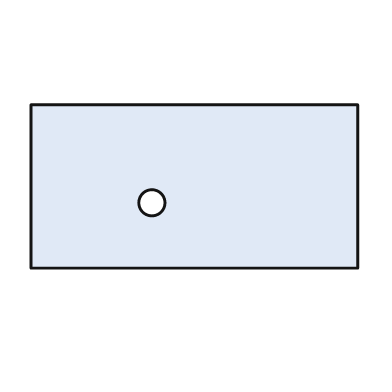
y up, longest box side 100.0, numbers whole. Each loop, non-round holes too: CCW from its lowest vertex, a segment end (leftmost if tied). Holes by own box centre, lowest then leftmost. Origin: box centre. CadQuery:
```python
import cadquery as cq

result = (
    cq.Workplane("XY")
    .moveTo(-50.0, -25.0)
    .lineTo(50.0, -25.0)
    .lineTo(50.0, 25.0)
    .lineTo(-50.0, 25.0)
    .close()
    .moveTo(-13.0, -5.0)
    .circle(4.0)
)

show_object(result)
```